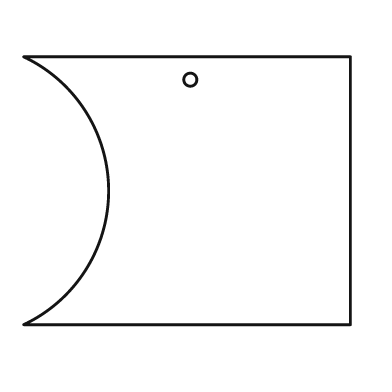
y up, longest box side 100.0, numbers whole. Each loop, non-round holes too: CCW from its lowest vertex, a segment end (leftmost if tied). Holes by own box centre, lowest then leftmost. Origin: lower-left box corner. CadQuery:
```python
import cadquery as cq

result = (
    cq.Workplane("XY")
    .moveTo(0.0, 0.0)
    .lineTo(100.0, 0.0)
    .lineTo(100.0, 82.0)
    .lineTo(0.0, 82.0)
    .threePointArc((26.0, 41.0), (0.0, 0.0))
    .close()
    .moveTo(51.0, 75.0)
    .circle(2.0)
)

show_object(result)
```